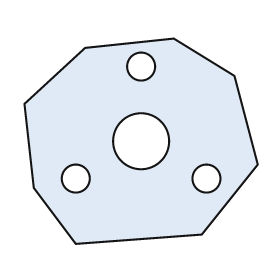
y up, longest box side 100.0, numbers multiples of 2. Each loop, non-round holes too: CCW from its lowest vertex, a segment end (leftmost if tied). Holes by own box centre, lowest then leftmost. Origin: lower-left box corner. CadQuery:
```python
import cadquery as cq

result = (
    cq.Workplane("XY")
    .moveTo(22.0, 0.0)
    .lineTo(76.0, 4.0)
    .lineTo(100.0, 34.0)
    .lineTo(90.0, 72.0)
    .lineTo(64.0, 88.0)
    .lineTo(26.0, 84.0)
    .lineTo(0.0, 60.0)
    .lineTo(4.0, 24.0)
    .close()
    .moveTo(22.0, 28.0)
    .circle(6.0)
    .moveTo(78.0, 28.0)
    .circle(6.0)
    .moveTo(50.0, 44.0)
    .circle(12.0)
    .moveTo(50.0, 76.0)
    .circle(6.0)
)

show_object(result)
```